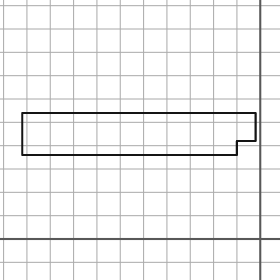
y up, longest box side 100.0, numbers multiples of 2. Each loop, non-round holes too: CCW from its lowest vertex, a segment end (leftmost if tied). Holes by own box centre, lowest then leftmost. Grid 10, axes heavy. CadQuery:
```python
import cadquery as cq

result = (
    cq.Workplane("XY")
    .moveTo(-102.0, 36.0)
    .lineTo(-10.0, 36.0)
    .lineTo(-10.0, 42.0)
    .lineTo(-2.0, 42.0)
    .lineTo(-2.0, 54.0)
    .lineTo(-102.0, 54.0)
    .close()
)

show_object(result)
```